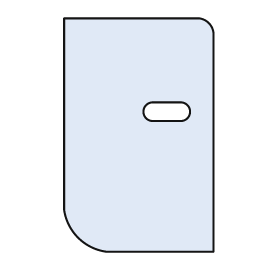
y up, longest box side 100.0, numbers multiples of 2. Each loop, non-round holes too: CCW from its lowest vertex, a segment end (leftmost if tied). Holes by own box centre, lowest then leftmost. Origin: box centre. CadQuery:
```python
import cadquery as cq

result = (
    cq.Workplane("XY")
    .moveTo(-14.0, -50.0)
    .lineTo(32.0, -50.0)
    .lineTo(32.0, 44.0)
    .threePointArc((30.0, 48.0), (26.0, 50.0))
    .lineTo(-32.0, 50.0)
    .lineTo(-32.0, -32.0)
    .threePointArc((-26.0, -44.0), (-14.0, -50.0))
    .close()
    .moveTo(6.0, 6.0)
    .lineTo(18.0, 6.0)
    .threePointArc((22.0, 10.0), (18.0, 14.0))
    .lineTo(6.0, 14.0)
    .threePointArc((2.0, 10.0), (6.0, 6.0))
    .close()
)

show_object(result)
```